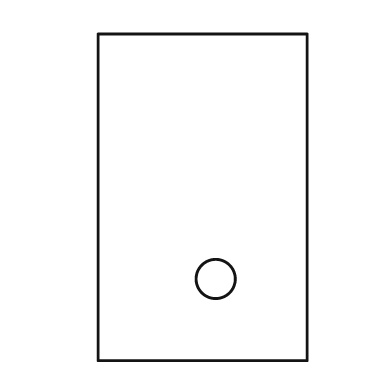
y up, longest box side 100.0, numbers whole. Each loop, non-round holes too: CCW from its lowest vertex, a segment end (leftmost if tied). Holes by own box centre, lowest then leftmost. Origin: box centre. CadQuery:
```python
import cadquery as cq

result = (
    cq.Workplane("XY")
    .moveTo(-32.0, -50.0)
    .lineTo(32.0, -50.0)
    .lineTo(32.0, 50.0)
    .lineTo(-32.0, 50.0)
    .close()
    .moveTo(4.0, -25.0)
    .circle(6.0)
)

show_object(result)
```